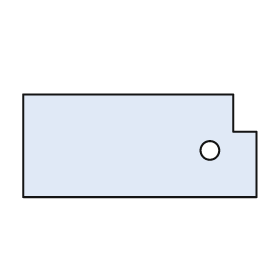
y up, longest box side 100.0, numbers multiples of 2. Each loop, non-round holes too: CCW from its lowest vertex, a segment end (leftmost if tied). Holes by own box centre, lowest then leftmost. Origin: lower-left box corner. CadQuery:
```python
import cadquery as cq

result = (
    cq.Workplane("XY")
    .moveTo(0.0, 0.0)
    .lineTo(100.0, 0.0)
    .lineTo(100.0, 28.0)
    .lineTo(90.0, 28.0)
    .lineTo(90.0, 44.0)
    .lineTo(0.0, 44.0)
    .close()
    .moveTo(80.0, 20.0)
    .circle(4.0)
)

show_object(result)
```